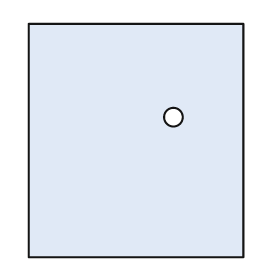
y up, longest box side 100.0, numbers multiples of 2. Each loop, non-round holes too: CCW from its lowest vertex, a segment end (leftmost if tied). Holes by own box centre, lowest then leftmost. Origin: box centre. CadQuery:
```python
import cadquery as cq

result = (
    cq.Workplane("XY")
    .moveTo(-46.0, -50.0)
    .lineTo(46.0, -50.0)
    .lineTo(46.0, 50.0)
    .lineTo(-46.0, 50.0)
    .close()
    .moveTo(16.0, 10.0)
    .circle(4.0)
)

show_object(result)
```